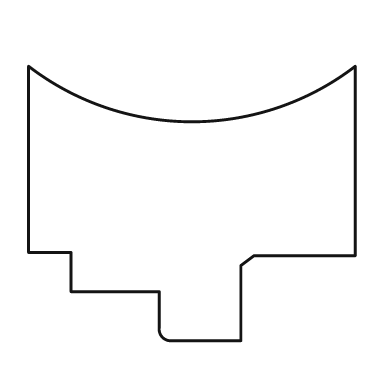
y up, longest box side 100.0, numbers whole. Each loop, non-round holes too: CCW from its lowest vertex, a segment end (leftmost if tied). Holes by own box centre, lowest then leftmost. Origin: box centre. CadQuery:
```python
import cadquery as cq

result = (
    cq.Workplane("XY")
    .moveTo(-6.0, -42.0)
    .lineTo(15.0, -42.0)
    .lineTo(15.0, -19.0)
    .lineTo(19.0, -16.0)
    .lineTo(50.0, -16.0)
    .lineTo(50.0, 42.0)
    .threePointArc((0.0, 25.0), (-50.0, 42.0))
    .lineTo(-50.0, -15.0)
    .lineTo(-37.0, -15.0)
    .lineTo(-37.0, -27.0)
    .lineTo(-10.0, -27.0)
    .lineTo(-10.0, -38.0)
    .threePointArc((-9.0, -41.0), (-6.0, -42.0))
    .close()
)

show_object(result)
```